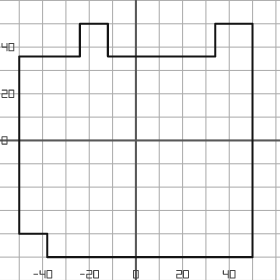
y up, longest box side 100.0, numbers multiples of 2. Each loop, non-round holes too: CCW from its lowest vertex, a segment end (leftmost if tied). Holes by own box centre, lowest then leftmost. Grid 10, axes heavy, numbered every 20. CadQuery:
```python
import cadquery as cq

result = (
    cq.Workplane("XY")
    .moveTo(-38.0, -50.0)
    .lineTo(50.0, -50.0)
    .lineTo(50.0, 50.0)
    .lineTo(34.0, 50.0)
    .lineTo(34.0, 36.0)
    .lineTo(-12.0, 36.0)
    .lineTo(-12.0, 50.0)
    .lineTo(-24.0, 50.0)
    .lineTo(-24.0, 36.0)
    .lineTo(-50.0, 36.0)
    .lineTo(-50.0, -40.0)
    .lineTo(-38.0, -40.0)
    .close()
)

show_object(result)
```